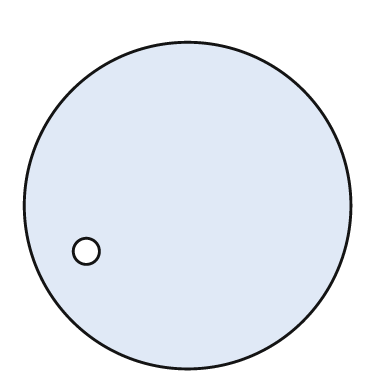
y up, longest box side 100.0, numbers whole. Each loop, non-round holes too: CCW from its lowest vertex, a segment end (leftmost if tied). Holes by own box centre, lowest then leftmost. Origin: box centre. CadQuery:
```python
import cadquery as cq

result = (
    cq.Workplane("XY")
    .moveTo(0.0, 0.0)
    .circle(50.0)
    .moveTo(-31.0, -14.0)
    .circle(4.0)
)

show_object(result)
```